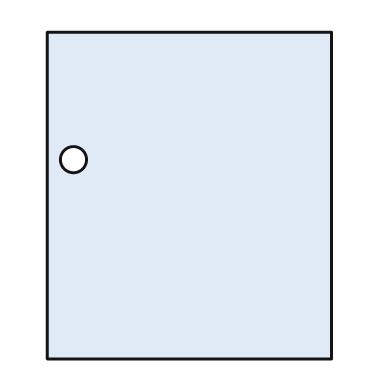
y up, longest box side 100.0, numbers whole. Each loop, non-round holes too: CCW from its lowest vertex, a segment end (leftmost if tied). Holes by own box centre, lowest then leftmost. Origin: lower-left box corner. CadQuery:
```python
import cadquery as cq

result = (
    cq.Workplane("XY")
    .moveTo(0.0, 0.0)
    .lineTo(87.0, 0.0)
    .lineTo(87.0, 100.0)
    .lineTo(0.0, 100.0)
    .close()
    .moveTo(8.0, 61.0)
    .circle(4.0)
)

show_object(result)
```